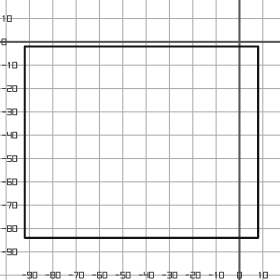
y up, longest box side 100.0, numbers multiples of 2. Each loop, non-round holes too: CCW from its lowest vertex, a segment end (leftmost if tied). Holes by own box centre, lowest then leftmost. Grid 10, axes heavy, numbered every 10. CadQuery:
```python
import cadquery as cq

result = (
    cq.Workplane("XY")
    .moveTo(-92.0, -84.0)
    .lineTo(8.0, -84.0)
    .lineTo(8.0, -2.0)
    .lineTo(-92.0, -2.0)
    .close()
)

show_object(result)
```